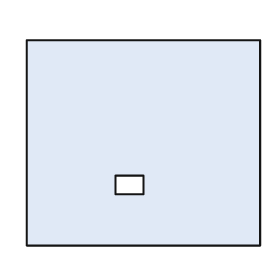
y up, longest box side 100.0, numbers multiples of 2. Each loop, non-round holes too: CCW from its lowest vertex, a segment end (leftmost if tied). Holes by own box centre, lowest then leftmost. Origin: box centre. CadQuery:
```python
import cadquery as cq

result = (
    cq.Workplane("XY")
    .moveTo(-50.0, -44.0)
    .lineTo(50.0, -44.0)
    .lineTo(50.0, 44.0)
    .lineTo(-50.0, 44.0)
    .close()
    .moveTo(-12.0, -22.0)
    .lineTo(0.0, -22.0)
    .lineTo(0.0, -14.0)
    .lineTo(-12.0, -14.0)
    .close()
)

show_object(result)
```